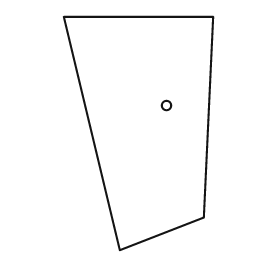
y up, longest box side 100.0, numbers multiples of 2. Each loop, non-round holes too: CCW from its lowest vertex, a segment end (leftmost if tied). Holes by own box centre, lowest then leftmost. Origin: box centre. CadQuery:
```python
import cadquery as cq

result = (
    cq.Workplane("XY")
    .moveTo(-8.0, -50.0)
    .lineTo(28.0, -36.0)
    .lineTo(32.0, 50.0)
    .lineTo(-32.0, 50.0)
    .close()
    .moveTo(12.0, 12.0)
    .circle(2.0)
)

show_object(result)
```